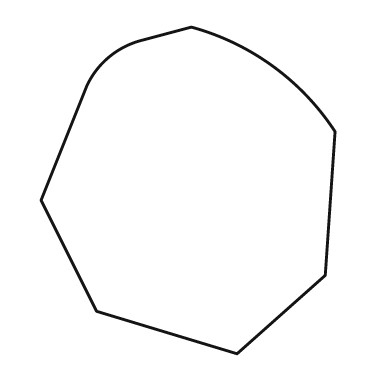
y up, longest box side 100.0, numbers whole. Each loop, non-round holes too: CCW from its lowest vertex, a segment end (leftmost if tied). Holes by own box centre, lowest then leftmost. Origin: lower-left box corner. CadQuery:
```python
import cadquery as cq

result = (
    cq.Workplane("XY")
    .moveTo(60.0, 0.0)
    .lineTo(87.0, 24.0)
    .lineTo(90.0, 68.0)
    .threePointArc((71.0, 88.0), (46.0, 100.0))
    .lineTo(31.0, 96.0)
    .threePointArc((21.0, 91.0), (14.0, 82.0))
    .lineTo(0.0, 47.0)
    .lineTo(17.0, 13.0)
    .close()
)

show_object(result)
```